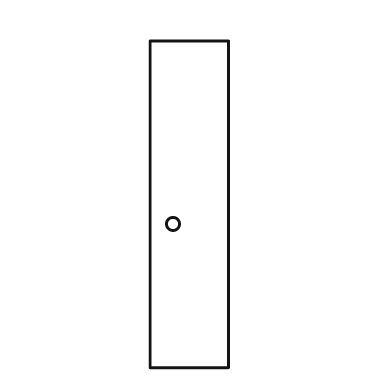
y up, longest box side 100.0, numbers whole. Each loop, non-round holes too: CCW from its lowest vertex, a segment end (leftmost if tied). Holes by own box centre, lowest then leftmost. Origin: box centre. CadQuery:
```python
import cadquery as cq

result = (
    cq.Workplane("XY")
    .moveTo(-12.0, -50.0)
    .lineTo(12.0, -50.0)
    .lineTo(12.0, 50.0)
    .lineTo(-12.0, 50.0)
    .close()
    .moveTo(-5.0, -6.0)
    .circle(2.0)
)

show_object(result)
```